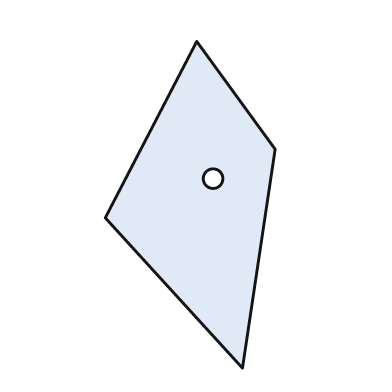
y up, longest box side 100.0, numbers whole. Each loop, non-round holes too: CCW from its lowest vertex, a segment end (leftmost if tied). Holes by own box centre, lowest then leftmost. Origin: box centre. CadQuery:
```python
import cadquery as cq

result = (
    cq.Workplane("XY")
    .moveTo(16.0, -50.0)
    .lineTo(26.0, 17.0)
    .lineTo(2.0, 50.0)
    .lineTo(-26.0, -4.0)
    .close()
    .moveTo(7.0, 8.0)
    .circle(3.0)
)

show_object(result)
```